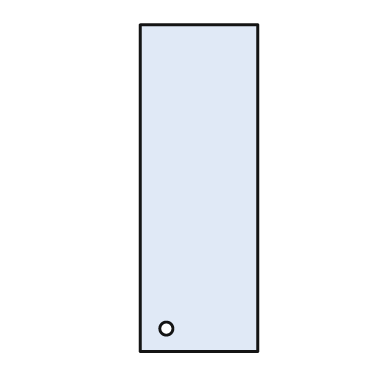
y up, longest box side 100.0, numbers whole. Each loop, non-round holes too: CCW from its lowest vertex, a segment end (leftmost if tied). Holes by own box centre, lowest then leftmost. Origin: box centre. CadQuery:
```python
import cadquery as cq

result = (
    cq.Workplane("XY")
    .moveTo(-18.0, -50.0)
    .lineTo(18.0, -50.0)
    .lineTo(18.0, 50.0)
    .lineTo(-18.0, 50.0)
    .close()
    .moveTo(-10.0, -43.0)
    .circle(2.0)
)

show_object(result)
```